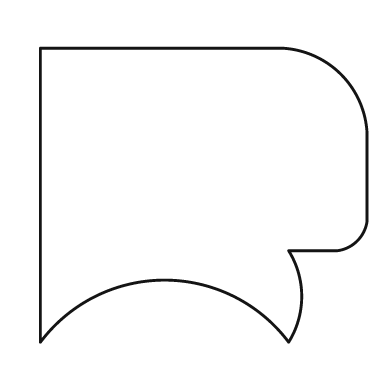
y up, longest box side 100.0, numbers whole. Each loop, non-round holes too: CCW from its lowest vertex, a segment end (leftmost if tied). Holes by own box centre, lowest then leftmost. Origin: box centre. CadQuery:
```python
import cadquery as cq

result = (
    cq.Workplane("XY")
    .moveTo(-50.0, -45.0)
    .threePointArc((-12.0, -26.0), (26.0, -45.0))
    .threePointArc((30.0, -31.0), (26.0, -17.0))
    .lineTo(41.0, -17.0)
    .threePointArc((47.0, -14.0), (50.0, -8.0))
    .lineTo(50.0, 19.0)
    .threePointArc((42.0, 37.0), (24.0, 45.0))
    .lineTo(-50.0, 45.0)
    .close()
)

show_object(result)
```